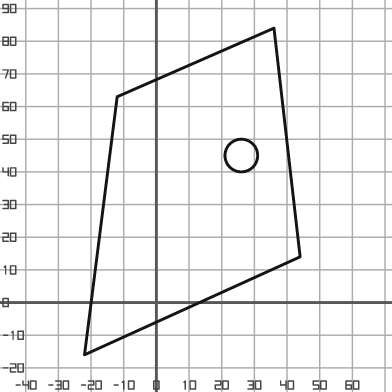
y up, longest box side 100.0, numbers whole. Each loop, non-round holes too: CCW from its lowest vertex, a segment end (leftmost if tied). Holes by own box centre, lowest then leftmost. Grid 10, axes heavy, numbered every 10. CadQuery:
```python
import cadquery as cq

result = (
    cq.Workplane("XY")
    .moveTo(-22.0, -16.0)
    .lineTo(44.0, 14.0)
    .lineTo(36.0, 84.0)
    .lineTo(-12.0, 63.0)
    .close()
    .moveTo(26.0, 45.0)
    .circle(5.0)
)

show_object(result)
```